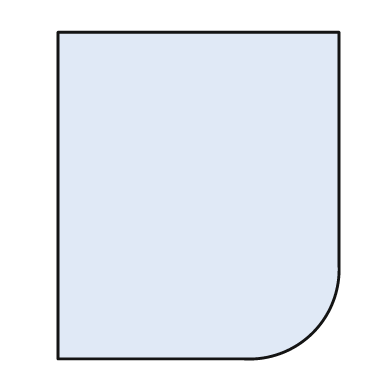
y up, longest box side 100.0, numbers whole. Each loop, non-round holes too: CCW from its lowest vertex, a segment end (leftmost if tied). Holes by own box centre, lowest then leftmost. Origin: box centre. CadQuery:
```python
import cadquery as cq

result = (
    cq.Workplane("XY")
    .moveTo(-43.0, -50.0)
    .lineTo(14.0, -50.0)
    .threePointArc((35.0, -42.0), (43.0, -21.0))
    .lineTo(43.0, 50.0)
    .lineTo(-43.0, 50.0)
    .close()
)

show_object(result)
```